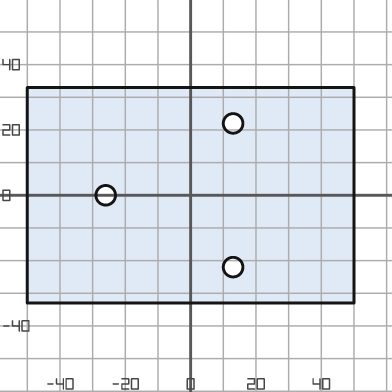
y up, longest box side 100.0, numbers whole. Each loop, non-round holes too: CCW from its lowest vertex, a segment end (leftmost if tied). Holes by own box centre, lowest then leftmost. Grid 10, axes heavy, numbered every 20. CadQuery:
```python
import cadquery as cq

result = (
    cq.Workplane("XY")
    .moveTo(-50.0, -33.0)
    .lineTo(50.0, -33.0)
    .lineTo(50.0, 33.0)
    .lineTo(-50.0, 33.0)
    .close()
    .moveTo(13.0, -22.0)
    .circle(3.0)
    .moveTo(-26.0, 0.0)
    .circle(3.0)
    .moveTo(13.0, 22.0)
    .circle(3.0)
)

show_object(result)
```